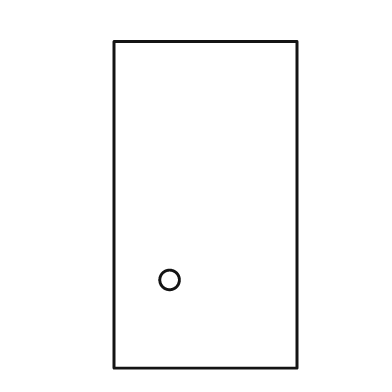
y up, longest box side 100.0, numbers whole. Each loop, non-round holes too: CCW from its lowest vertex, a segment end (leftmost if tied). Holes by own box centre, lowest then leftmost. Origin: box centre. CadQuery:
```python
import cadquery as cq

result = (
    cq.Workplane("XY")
    .moveTo(-28.0, -50.0)
    .lineTo(28.0, -50.0)
    .lineTo(28.0, 50.0)
    .lineTo(-28.0, 50.0)
    .close()
    .moveTo(-11.0, -23.0)
    .circle(3.0)
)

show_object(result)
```